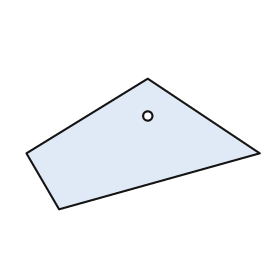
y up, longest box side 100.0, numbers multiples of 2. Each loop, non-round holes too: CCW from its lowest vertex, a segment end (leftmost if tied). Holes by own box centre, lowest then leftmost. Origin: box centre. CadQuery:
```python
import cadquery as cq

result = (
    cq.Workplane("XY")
    .moveTo(-36.0, -28.0)
    .lineTo(50.0, -4.0)
    .lineTo(2.0, 28.0)
    .lineTo(-50.0, -4.0)
    .close()
    .moveTo(2.0, 12.0)
    .circle(2.0)
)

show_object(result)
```